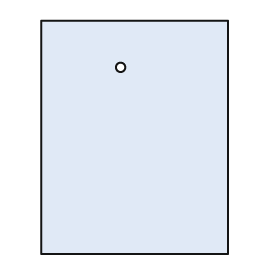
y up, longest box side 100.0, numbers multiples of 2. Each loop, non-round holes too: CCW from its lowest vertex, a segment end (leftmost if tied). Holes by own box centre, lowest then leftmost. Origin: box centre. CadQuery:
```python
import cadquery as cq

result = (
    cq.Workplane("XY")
    .moveTo(-40.0, -50.0)
    .lineTo(40.0, -50.0)
    .lineTo(40.0, 50.0)
    .lineTo(-40.0, 50.0)
    .close()
    .moveTo(-6.0, 30.0)
    .circle(2.0)
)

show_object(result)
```